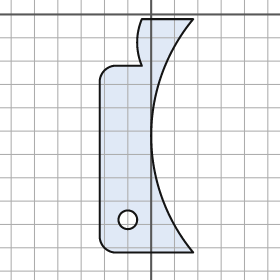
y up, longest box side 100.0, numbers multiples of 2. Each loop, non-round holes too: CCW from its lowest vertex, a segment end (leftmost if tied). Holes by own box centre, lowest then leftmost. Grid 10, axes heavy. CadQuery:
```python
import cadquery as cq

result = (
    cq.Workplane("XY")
    .moveTo(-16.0, -102.0)
    .lineTo(18.0, -102.0)
    .threePointArc((0.0, -52.0), (18.0, -2.0))
    .lineTo(-4.0, -2.0)
    .threePointArc((-6.0, -12.0), (-4.0, -22.0))
    .lineTo(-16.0, -22.0)
    .threePointArc((-20.0, -24.0), (-22.0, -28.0))
    .lineTo(-22.0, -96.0)
    .threePointArc((-20.0, -100.0), (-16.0, -102.0))
    .close()
    .moveTo(-10.0, -88.0)
    .circle(4.0)
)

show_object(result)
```